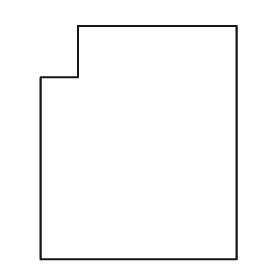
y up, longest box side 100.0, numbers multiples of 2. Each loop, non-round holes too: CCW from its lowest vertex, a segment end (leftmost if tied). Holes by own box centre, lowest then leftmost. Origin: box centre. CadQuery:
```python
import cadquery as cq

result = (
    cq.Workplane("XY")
    .moveTo(-42.0, -50.0)
    .lineTo(42.0, -50.0)
    .lineTo(42.0, 50.0)
    .lineTo(-26.0, 50.0)
    .lineTo(-26.0, 28.0)
    .lineTo(-42.0, 28.0)
    .close()
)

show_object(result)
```